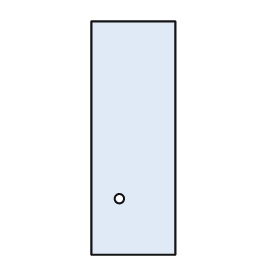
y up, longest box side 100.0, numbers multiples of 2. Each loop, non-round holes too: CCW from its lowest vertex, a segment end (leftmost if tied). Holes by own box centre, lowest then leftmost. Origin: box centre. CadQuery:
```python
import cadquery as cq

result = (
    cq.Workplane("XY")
    .moveTo(-18.0, -50.0)
    .lineTo(18.0, -50.0)
    .lineTo(18.0, 50.0)
    .lineTo(-18.0, 50.0)
    .close()
    .moveTo(-6.0, -26.0)
    .circle(2.0)
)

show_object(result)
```